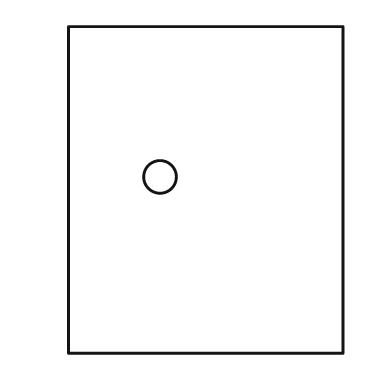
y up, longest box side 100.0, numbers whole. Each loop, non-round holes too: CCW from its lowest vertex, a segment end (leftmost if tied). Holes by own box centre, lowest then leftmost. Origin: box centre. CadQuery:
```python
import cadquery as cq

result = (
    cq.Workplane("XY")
    .moveTo(-42.0, -50.0)
    .lineTo(42.0, -50.0)
    .lineTo(42.0, 50.0)
    .lineTo(-42.0, 50.0)
    .close()
    .moveTo(-14.0, 4.0)
    .circle(5.0)
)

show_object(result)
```